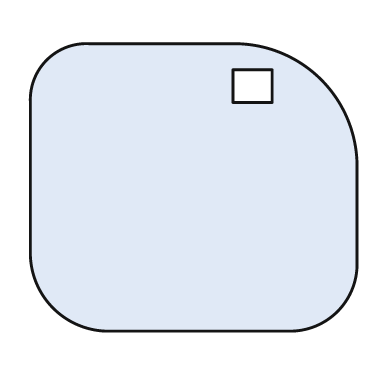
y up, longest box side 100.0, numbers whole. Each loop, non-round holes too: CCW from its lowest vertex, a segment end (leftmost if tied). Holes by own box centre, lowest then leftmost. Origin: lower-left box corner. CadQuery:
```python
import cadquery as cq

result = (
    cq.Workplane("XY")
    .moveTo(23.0, 0.0)
    .lineTo(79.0, 0.0)
    .threePointArc((94.0, 6.0), (100.0, 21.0))
    .lineTo(100.0, 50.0)
    .threePointArc((89.0, 77.0), (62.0, 88.0))
    .lineTo(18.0, 88.0)
    .threePointArc((5.0, 83.0), (0.0, 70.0))
    .lineTo(0.0, 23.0)
    .threePointArc((7.0, 7.0), (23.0, 0.0))
    .close()
    .moveTo(62.0, 70.0)
    .lineTo(74.0, 70.0)
    .lineTo(74.0, 80.0)
    .lineTo(62.0, 80.0)
    .close()
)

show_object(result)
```